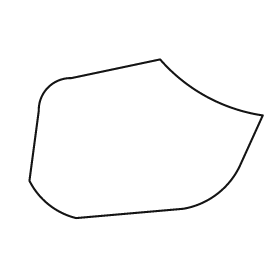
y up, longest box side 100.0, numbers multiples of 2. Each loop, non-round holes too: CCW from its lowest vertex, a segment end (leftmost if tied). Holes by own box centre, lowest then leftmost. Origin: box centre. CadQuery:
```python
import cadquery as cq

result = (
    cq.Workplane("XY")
    .moveTo(-30.0, -34.0)
    .lineTo(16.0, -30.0)
    .threePointArc((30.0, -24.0), (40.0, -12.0))
    .lineTo(50.0, 10.0)
    .threePointArc((26.0, 18.0), (6.0, 34.0))
    .lineTo(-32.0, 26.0)
    .threePointArc((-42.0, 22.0), (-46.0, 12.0))
    .lineTo(-50.0, -18.0)
    .threePointArc((-42.0, -28.0), (-30.0, -34.0))
    .close()
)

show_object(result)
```